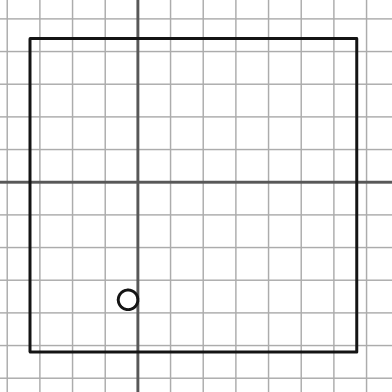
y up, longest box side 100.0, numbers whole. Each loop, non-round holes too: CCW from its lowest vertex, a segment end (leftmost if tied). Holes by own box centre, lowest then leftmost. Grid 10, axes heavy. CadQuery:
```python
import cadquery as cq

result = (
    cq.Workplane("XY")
    .moveTo(-33.0, -52.0)
    .lineTo(67.0, -52.0)
    .lineTo(67.0, 44.0)
    .lineTo(-33.0, 44.0)
    .close()
    .moveTo(-3.0, -36.0)
    .circle(3.0)
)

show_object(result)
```